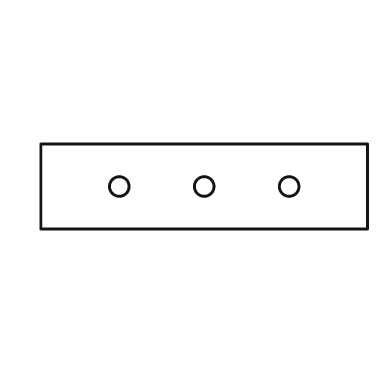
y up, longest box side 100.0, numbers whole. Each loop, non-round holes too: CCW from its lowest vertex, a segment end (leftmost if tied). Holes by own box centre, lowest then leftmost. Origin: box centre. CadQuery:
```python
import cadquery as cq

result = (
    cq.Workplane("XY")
    .moveTo(-50.0, -13.0)
    .lineTo(50.0, -13.0)
    .lineTo(50.0, 13.0)
    .lineTo(-50.0, 13.0)
    .close()
    .moveTo(-26.0, 0.0)
    .circle(3.0)
    .moveTo(0.0, 0.0)
    .circle(3.0)
    .moveTo(26.0, 0.0)
    .circle(3.0)
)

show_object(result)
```